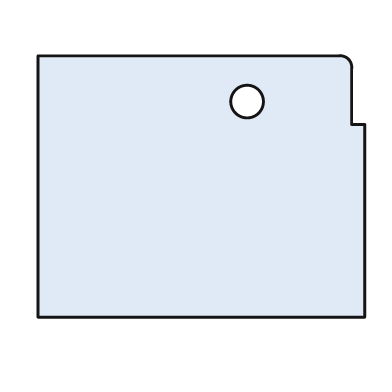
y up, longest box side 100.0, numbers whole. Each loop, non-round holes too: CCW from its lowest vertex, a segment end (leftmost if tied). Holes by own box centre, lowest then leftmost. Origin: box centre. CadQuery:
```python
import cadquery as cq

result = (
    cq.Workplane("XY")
    .moveTo(-50.0, -40.0)
    .lineTo(50.0, -40.0)
    .lineTo(50.0, 19.0)
    .lineTo(46.0, 19.0)
    .lineTo(46.0, 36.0)
    .threePointArc((45.0, 39.0), (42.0, 40.0))
    .lineTo(-50.0, 40.0)
    .close()
    .moveTo(14.0, 26.0)
    .circle(5.0)
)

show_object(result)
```